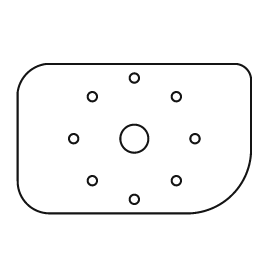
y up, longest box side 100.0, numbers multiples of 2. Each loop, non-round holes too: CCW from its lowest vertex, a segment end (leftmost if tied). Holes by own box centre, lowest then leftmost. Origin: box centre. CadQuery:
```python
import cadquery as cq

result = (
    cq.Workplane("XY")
    .moveTo(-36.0, -32.0)
    .lineTo(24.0, -32.0)
    .threePointArc((42.0, -24.0), (50.0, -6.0))
    .lineTo(50.0, 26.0)
    .threePointArc((48.0, 30.0), (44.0, 32.0))
    .lineTo(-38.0, 32.0)
    .threePointArc((-46.0, 28.0), (-50.0, 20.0))
    .lineTo(-50.0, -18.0)
    .threePointArc((-46.0, -28.0), (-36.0, -32.0))
    .close()
    .moveTo(0.0, -26.0)
    .circle(2.0)
    .moveTo(-18.0, -18.0)
    .circle(2.0)
    .moveTo(18.0, -18.0)
    .circle(2.0)
    .moveTo(-26.0, 0.0)
    .circle(2.0)
    .moveTo(0.0, 0.0)
    .circle(6.0)
    .moveTo(26.0, 0.0)
    .circle(2.0)
    .moveTo(-18.0, 18.0)
    .circle(2.0)
    .moveTo(18.0, 18.0)
    .circle(2.0)
    .moveTo(0.0, 26.0)
    .circle(2.0)
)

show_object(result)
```